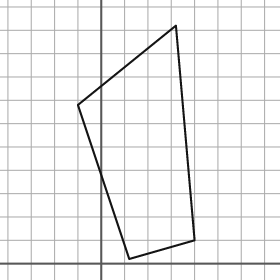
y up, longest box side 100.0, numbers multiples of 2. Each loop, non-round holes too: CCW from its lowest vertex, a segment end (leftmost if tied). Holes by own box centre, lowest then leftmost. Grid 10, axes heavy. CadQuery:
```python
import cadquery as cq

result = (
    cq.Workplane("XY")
    .moveTo(12.0, 2.0)
    .lineTo(40.0, 10.0)
    .lineTo(32.0, 102.0)
    .lineTo(-10.0, 68.0)
    .close()
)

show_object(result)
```